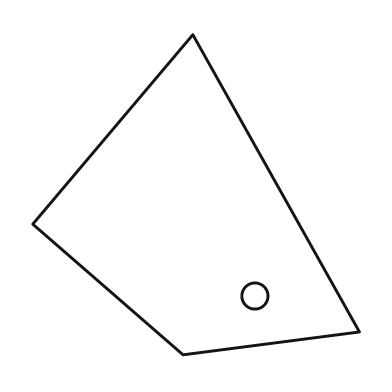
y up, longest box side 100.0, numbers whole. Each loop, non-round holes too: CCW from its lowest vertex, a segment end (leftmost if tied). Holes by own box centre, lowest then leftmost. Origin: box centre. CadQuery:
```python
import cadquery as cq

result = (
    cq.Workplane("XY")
    .moveTo(-4.0, -49.0)
    .lineTo(50.0, -42.0)
    .lineTo(-1.0, 49.0)
    .lineTo(-50.0, -9.0)
    .close()
    .moveTo(18.0, -31.0)
    .circle(4.0)
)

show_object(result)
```